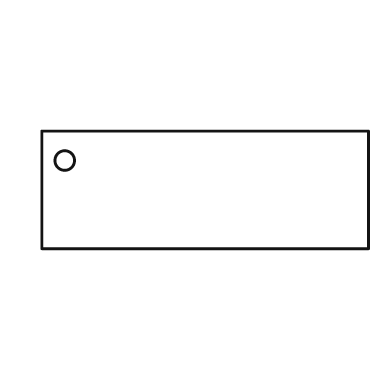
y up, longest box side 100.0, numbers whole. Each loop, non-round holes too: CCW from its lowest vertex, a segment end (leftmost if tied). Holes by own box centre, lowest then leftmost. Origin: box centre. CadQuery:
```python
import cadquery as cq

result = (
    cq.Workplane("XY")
    .moveTo(-50.0, -18.0)
    .lineTo(50.0, -18.0)
    .lineTo(50.0, 18.0)
    .lineTo(-50.0, 18.0)
    .close()
    .moveTo(-43.0, 9.0)
    .circle(3.0)
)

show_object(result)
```